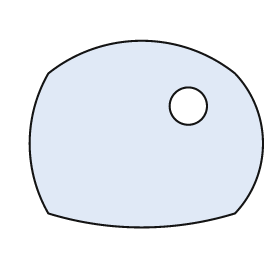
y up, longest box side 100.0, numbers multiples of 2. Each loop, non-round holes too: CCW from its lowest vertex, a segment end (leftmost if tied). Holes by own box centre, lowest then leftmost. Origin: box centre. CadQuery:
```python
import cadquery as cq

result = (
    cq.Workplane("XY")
    .moveTo(-42.0, -34.0)
    .threePointArc((-2.0, -40.0), (38.0, -34.0))
    .threePointArc((50.0, -4.0), (38.0, 26.0))
    .threePointArc((-2.0, 40.0), (-42.0, 26.0))
    .threePointArc((-50.0, -4.0), (-42.0, -34.0))
    .close()
    .moveTo(18.0, 12.0)
    .circle(8.0)
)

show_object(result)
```